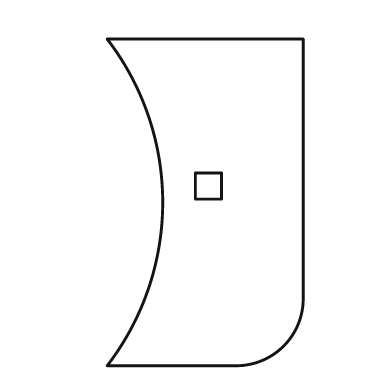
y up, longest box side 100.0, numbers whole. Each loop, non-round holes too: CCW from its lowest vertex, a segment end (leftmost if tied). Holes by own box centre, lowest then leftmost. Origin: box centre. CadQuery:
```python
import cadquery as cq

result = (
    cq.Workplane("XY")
    .moveTo(-30.0, -50.0)
    .lineTo(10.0, -50.0)
    .threePointArc((24.0, -44.0), (30.0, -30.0))
    .lineTo(30.0, 50.0)
    .lineTo(-30.0, 50.0)
    .threePointArc((-13.0, 0.0), (-30.0, -50.0))
    .close()
    .moveTo(-3.0, 1.0)
    .lineTo(5.0, 1.0)
    .lineTo(5.0, 9.0)
    .lineTo(-3.0, 9.0)
    .close()
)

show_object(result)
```